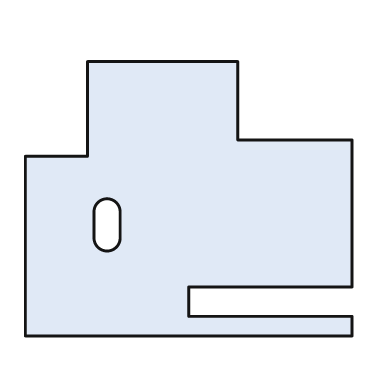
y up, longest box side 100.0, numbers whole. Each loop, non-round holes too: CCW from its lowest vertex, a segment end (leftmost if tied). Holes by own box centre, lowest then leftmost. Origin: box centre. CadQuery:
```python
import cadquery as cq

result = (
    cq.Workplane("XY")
    .moveTo(-50.0, -42.0)
    .lineTo(50.0, -42.0)
    .lineTo(50.0, -36.0)
    .lineTo(0.0, -36.0)
    .lineTo(0.0, -27.0)
    .lineTo(50.0, -27.0)
    .lineTo(50.0, 18.0)
    .lineTo(15.0, 18.0)
    .lineTo(15.0, 42.0)
    .lineTo(-31.0, 42.0)
    .lineTo(-31.0, 13.0)
    .lineTo(-50.0, 13.0)
    .close()
    .moveTo(-29.0, -12.0)
    .threePointArc((-25.0, -16.0), (-21.0, -12.0))
    .lineTo(-21.0, -4.0)
    .threePointArc((-25.0, 0.0), (-29.0, -4.0))
    .close()
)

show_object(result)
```